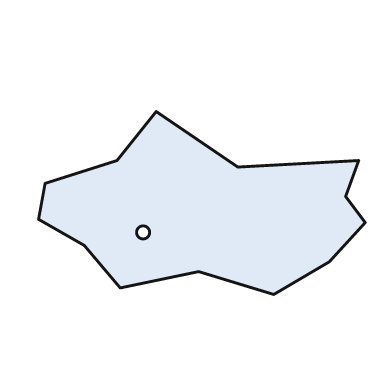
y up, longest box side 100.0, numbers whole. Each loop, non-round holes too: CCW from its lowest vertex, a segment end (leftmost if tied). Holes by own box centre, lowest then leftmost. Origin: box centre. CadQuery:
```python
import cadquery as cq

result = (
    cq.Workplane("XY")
    .moveTo(22.0, -28.0)
    .lineTo(39.0, -18.0)
    .lineTo(50.0, -6.0)
    .lineTo(44.0, 2.0)
    .lineTo(48.0, 13.0)
    .lineTo(11.0, 11.0)
    .lineTo(-14.0, 28.0)
    .lineTo(-26.0, 13.0)
    .lineTo(-48.0, 6.0)
    .lineTo(-50.0, -5.0)
    .lineTo(-36.0, -13.0)
    .lineTo(-25.0, -26.0)
    .lineTo(-1.0, -21.0)
    .close()
    .moveTo(-18.0, -9.0)
    .circle(2.0)
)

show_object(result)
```